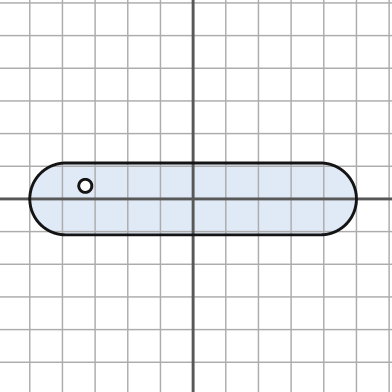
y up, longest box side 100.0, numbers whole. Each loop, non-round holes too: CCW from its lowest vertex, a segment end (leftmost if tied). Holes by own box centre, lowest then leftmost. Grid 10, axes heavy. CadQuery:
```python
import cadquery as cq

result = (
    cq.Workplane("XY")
    .moveTo(-39.0, -11.0)
    .lineTo(39.0, -11.0)
    .threePointArc((50.0, 0.0), (39.0, 11.0))
    .lineTo(-39.0, 11.0)
    .threePointArc((-50.0, 0.0), (-39.0, -11.0))
    .close()
    .moveTo(-33.0, 4.0)
    .circle(2.0)
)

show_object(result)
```